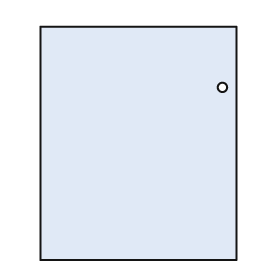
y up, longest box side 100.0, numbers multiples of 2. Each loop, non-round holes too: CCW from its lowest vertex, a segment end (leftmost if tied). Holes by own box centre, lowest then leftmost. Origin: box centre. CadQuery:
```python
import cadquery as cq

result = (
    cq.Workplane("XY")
    .moveTo(-42.0, -50.0)
    .lineTo(42.0, -50.0)
    .lineTo(42.0, 50.0)
    .lineTo(-42.0, 50.0)
    .close()
    .moveTo(36.0, 24.0)
    .circle(2.0)
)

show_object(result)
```